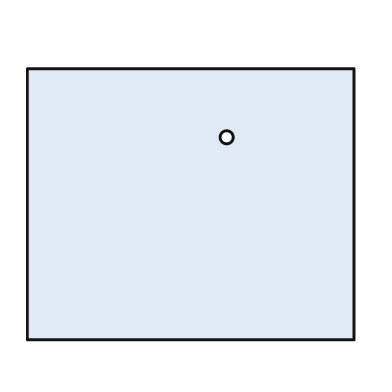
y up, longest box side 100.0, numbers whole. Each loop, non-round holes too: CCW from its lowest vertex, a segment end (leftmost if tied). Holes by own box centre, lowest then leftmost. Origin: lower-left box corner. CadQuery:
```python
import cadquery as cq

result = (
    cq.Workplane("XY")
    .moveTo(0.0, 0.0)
    .lineTo(100.0, 0.0)
    .lineTo(100.0, 83.0)
    .lineTo(0.0, 83.0)
    .close()
    .moveTo(61.0, 62.0)
    .circle(2.0)
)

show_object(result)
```